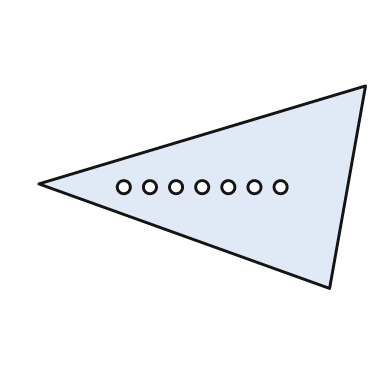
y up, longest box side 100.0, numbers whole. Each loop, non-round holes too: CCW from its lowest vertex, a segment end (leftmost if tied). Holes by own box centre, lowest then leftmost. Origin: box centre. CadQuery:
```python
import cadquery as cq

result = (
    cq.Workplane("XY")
    .moveTo(39.0, -31.0)
    .lineTo(50.0, 31.0)
    .lineTo(-50.0, 1.0)
    .close()
    .moveTo(-24.0, 0.0)
    .circle(2.0)
    .moveTo(-16.0, 0.0)
    .circle(2.0)
    .moveTo(-8.0, 0.0)
    .circle(2.0)
    .moveTo(0.0, 0.0)
    .circle(2.0)
    .moveTo(8.0, 0.0)
    .circle(2.0)
    .moveTo(16.0, 0.0)
    .circle(2.0)
    .moveTo(24.0, 0.0)
    .circle(2.0)
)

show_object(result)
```